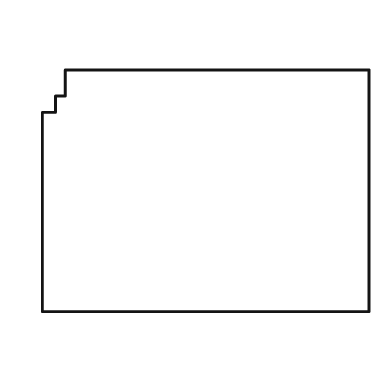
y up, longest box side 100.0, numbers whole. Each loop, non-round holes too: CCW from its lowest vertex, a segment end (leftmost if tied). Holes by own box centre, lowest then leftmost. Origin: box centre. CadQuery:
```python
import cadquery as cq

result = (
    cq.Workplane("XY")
    .moveTo(-50.0, -37.0)
    .lineTo(50.0, -37.0)
    .lineTo(50.0, 37.0)
    .lineTo(-43.0, 37.0)
    .lineTo(-43.0, 29.0)
    .lineTo(-46.0, 29.0)
    .lineTo(-46.0, 24.0)
    .lineTo(-50.0, 24.0)
    .close()
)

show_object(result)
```